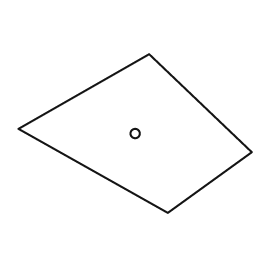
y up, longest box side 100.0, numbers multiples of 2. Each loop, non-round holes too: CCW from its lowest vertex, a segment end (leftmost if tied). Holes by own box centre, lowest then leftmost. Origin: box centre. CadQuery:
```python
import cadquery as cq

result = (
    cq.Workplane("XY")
    .moveTo(14.0, -34.0)
    .lineTo(50.0, -8.0)
    .lineTo(6.0, 34.0)
    .lineTo(-50.0, 2.0)
    .close()
    .moveTo(0.0, 0.0)
    .circle(2.0)
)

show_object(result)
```